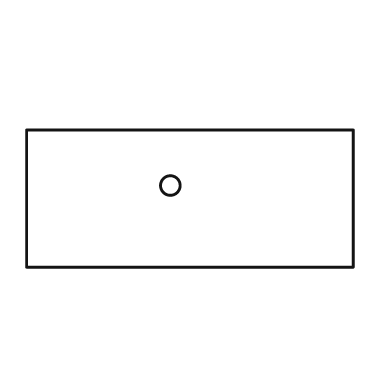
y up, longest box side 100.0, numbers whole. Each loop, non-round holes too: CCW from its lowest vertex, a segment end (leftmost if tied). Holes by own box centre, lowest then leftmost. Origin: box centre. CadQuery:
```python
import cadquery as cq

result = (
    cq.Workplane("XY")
    .moveTo(-50.0, -21.0)
    .lineTo(50.0, -21.0)
    .lineTo(50.0, 21.0)
    .lineTo(-50.0, 21.0)
    .close()
    .moveTo(-6.0, 4.0)
    .circle(3.0)
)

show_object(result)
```